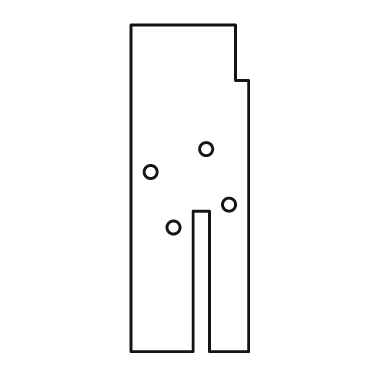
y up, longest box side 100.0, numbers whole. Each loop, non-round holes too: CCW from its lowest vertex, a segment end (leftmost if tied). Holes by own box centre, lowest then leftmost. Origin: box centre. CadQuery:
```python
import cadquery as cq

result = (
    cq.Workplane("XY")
    .moveTo(-18.0, -50.0)
    .lineTo(1.0, -50.0)
    .lineTo(1.0, -7.0)
    .lineTo(6.0, -7.0)
    .lineTo(6.0, -50.0)
    .lineTo(18.0, -50.0)
    .lineTo(18.0, 33.0)
    .lineTo(14.0, 33.0)
    .lineTo(14.0, 50.0)
    .lineTo(-18.0, 50.0)
    .close()
    .moveTo(-5.0, -12.0)
    .circle(2.0)
    .moveTo(12.0, -5.0)
    .circle(2.0)
    .moveTo(-12.0, 5.0)
    .circle(2.0)
    .moveTo(5.0, 12.0)
    .circle(2.0)
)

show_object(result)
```